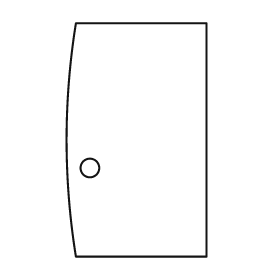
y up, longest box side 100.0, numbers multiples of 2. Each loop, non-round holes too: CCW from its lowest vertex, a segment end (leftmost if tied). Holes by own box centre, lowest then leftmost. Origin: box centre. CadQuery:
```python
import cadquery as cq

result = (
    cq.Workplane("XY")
    .moveTo(-26.0, -50.0)
    .lineTo(30.0, -50.0)
    .lineTo(30.0, 50.0)
    .lineTo(-26.0, 50.0)
    .threePointArc((-30.0, 0.0), (-26.0, -50.0))
    .close()
    .moveTo(-20.0, -12.0)
    .circle(4.0)
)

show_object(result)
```